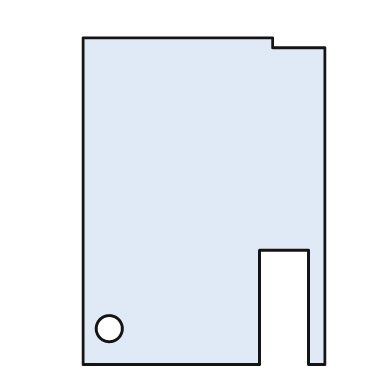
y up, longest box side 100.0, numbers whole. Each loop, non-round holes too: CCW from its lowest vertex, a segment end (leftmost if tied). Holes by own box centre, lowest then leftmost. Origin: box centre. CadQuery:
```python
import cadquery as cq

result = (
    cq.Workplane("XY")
    .moveTo(-37.0, -50.0)
    .lineTo(17.0, -50.0)
    .lineTo(17.0, -15.0)
    .lineTo(32.0, -15.0)
    .lineTo(32.0, -50.0)
    .lineTo(37.0, -50.0)
    .lineTo(37.0, 47.0)
    .lineTo(21.0, 47.0)
    .lineTo(21.0, 50.0)
    .lineTo(-37.0, 50.0)
    .close()
    .moveTo(-29.0, -39.0)
    .circle(4.0)
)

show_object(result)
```